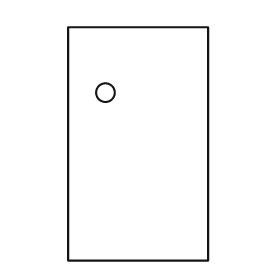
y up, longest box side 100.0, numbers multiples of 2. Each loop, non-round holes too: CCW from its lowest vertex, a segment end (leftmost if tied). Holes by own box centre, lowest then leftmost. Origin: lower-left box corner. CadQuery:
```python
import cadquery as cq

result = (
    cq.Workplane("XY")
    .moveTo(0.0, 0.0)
    .lineTo(60.0, 0.0)
    .lineTo(60.0, 100.0)
    .lineTo(0.0, 100.0)
    .close()
    .moveTo(16.0, 72.0)
    .circle(4.0)
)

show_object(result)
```